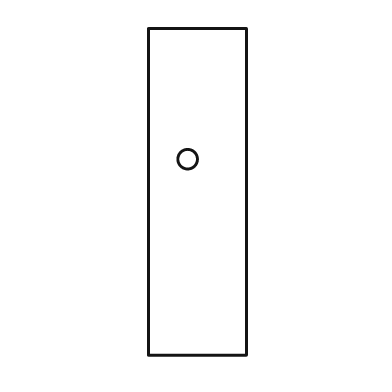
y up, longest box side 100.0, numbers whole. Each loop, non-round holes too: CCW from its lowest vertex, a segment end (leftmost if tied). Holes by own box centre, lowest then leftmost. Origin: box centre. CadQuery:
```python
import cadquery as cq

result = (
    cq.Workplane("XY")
    .moveTo(-15.0, -50.0)
    .lineTo(15.0, -50.0)
    .lineTo(15.0, 50.0)
    .lineTo(-15.0, 50.0)
    .close()
    .moveTo(-3.0, 10.0)
    .circle(3.0)
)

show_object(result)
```